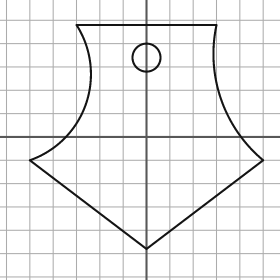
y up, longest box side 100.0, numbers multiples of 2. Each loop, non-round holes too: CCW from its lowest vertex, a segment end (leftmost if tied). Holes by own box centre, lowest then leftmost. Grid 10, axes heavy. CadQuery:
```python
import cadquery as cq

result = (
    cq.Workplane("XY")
    .moveTo(0.0, -48.0)
    .lineTo(50.0, -10.0)
    .threePointArc((32.0, 16.0), (30.0, 48.0))
    .lineTo(-30.0, 48.0)
    .threePointArc((-26.0, 14.0), (-50.0, -10.0))
    .close()
    .moveTo(0.0, 34.0)
    .circle(6.0)
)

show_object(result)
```